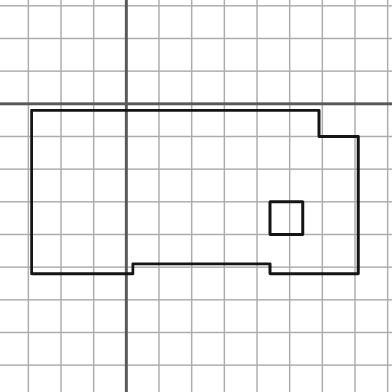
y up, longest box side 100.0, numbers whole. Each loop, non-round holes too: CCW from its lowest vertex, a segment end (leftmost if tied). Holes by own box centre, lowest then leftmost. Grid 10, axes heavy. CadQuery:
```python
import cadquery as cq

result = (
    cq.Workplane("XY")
    .moveTo(-29.0, -52.0)
    .lineTo(2.0, -52.0)
    .lineTo(2.0, -49.0)
    .lineTo(44.0, -49.0)
    .lineTo(44.0, -52.0)
    .lineTo(71.0, -52.0)
    .lineTo(71.0, -10.0)
    .lineTo(59.0, -10.0)
    .lineTo(59.0, -2.0)
    .lineTo(-29.0, -2.0)
    .close()
    .moveTo(44.0, -40.0)
    .lineTo(54.0, -40.0)
    .lineTo(54.0, -30.0)
    .lineTo(44.0, -30.0)
    .close()
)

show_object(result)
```